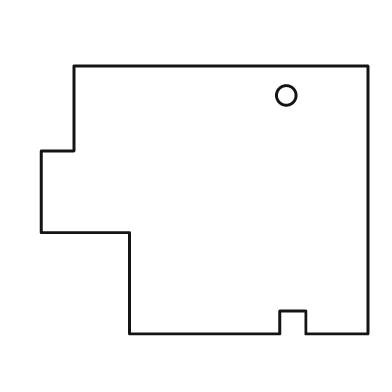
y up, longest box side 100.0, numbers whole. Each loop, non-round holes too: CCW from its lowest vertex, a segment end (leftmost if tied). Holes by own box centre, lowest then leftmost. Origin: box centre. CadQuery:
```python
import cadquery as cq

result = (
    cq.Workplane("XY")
    .moveTo(-23.0, -41.0)
    .lineTo(23.0, -41.0)
    .lineTo(23.0, -34.0)
    .lineTo(31.0, -34.0)
    .lineTo(31.0, -41.0)
    .lineTo(50.0, -41.0)
    .lineTo(50.0, 41.0)
    .lineTo(-40.0, 41.0)
    .lineTo(-40.0, 15.0)
    .lineTo(-50.0, 15.0)
    .lineTo(-50.0, -10.0)
    .lineTo(-23.0, -10.0)
    .close()
    .moveTo(25.0, 32.0)
    .circle(3.0)
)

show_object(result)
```